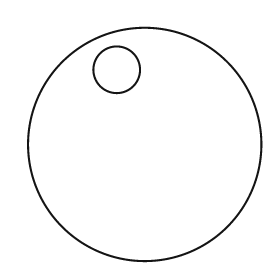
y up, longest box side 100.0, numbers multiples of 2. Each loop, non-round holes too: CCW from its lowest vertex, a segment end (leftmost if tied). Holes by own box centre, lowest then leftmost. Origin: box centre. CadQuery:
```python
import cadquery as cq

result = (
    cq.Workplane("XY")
    .moveTo(0.0, 0.0)
    .circle(50.0)
    .moveTo(-12.0, 32.0)
    .circle(10.0)
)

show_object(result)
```